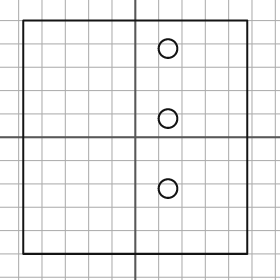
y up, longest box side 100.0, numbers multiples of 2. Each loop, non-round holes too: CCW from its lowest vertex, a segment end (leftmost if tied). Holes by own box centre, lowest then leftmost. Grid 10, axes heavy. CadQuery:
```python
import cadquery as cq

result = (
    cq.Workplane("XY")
    .moveTo(-48.0, -50.0)
    .lineTo(48.0, -50.0)
    .lineTo(48.0, 50.0)
    .lineTo(-48.0, 50.0)
    .close()
    .moveTo(14.0, -22.0)
    .circle(4.0)
    .moveTo(14.0, 8.0)
    .circle(4.0)
    .moveTo(14.0, 38.0)
    .circle(4.0)
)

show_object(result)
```